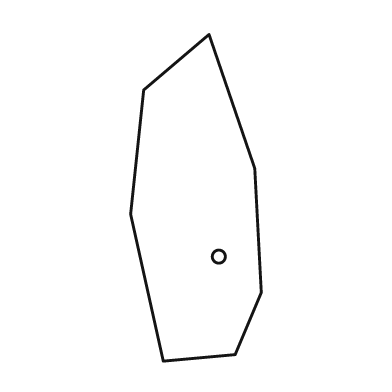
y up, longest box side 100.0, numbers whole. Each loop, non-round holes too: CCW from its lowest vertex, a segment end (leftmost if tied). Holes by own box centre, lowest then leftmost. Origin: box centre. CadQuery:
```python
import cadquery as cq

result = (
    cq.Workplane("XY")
    .moveTo(-10.0, -50.0)
    .lineTo(12.0, -48.0)
    .lineTo(20.0, -29.0)
    .lineTo(18.0, 9.0)
    .lineTo(4.0, 50.0)
    .lineTo(-16.0, 33.0)
    .lineTo(-20.0, -5.0)
    .close()
    .moveTo(7.0, -18.0)
    .circle(2.0)
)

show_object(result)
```